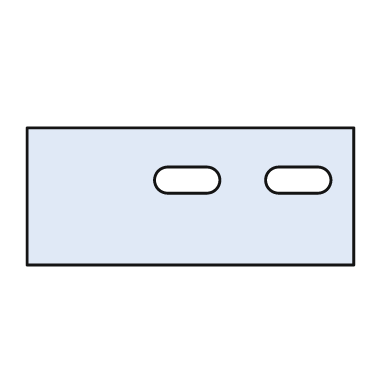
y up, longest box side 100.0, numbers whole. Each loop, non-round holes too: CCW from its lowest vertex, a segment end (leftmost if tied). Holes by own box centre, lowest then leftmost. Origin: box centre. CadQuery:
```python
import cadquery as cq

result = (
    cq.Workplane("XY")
    .moveTo(-50.0, -21.0)
    .lineTo(50.0, -21.0)
    .lineTo(50.0, 21.0)
    .lineTo(-50.0, 21.0)
    .close()
    .moveTo(-7.0, 1.0)
    .lineTo(5.0, 1.0)
    .threePointArc((9.0, 5.0), (5.0, 9.0))
    .lineTo(-7.0, 9.0)
    .threePointArc((-11.0, 5.0), (-7.0, 1.0))
    .close()
    .moveTo(27.0, 1.0)
    .lineTo(39.0, 1.0)
    .threePointArc((43.0, 5.0), (39.0, 9.0))
    .lineTo(27.0, 9.0)
    .threePointArc((23.0, 5.0), (27.0, 1.0))
    .close()
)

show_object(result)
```